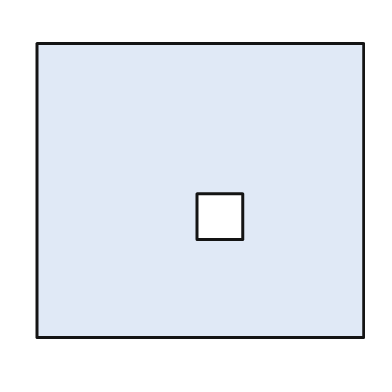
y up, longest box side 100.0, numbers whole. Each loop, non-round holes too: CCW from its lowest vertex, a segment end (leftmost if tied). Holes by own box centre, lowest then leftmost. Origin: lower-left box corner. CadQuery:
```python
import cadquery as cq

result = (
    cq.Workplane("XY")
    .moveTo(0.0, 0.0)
    .lineTo(100.0, 0.0)
    .lineTo(100.0, 90.0)
    .lineTo(0.0, 90.0)
    .close()
    .moveTo(49.0, 30.0)
    .lineTo(63.0, 30.0)
    .lineTo(63.0, 44.0)
    .lineTo(49.0, 44.0)
    .close()
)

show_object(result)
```